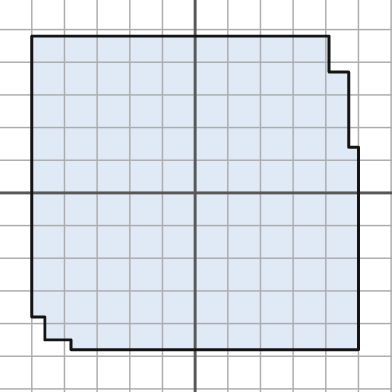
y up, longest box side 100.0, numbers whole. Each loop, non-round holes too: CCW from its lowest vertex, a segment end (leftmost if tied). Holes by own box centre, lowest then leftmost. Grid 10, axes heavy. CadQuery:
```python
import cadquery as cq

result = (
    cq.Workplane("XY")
    .moveTo(-38.0, -48.0)
    .lineTo(50.0, -48.0)
    .lineTo(50.0, 14.0)
    .lineTo(47.0, 14.0)
    .lineTo(47.0, 37.0)
    .lineTo(41.0, 37.0)
    .lineTo(41.0, 48.0)
    .lineTo(-50.0, 48.0)
    .lineTo(-50.0, -38.0)
    .lineTo(-46.0, -38.0)
    .lineTo(-46.0, -45.0)
    .lineTo(-38.0, -45.0)
    .close()
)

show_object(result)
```